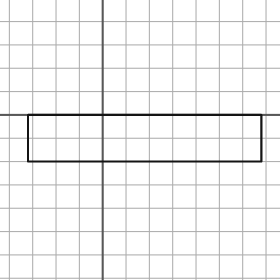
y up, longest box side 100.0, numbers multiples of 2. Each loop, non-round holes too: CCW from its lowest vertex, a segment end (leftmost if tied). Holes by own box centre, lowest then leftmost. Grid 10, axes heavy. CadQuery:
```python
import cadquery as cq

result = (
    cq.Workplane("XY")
    .moveTo(-32.0, -20.0)
    .lineTo(68.0, -20.0)
    .lineTo(68.0, 0.0)
    .lineTo(-32.0, 0.0)
    .close()
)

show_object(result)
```